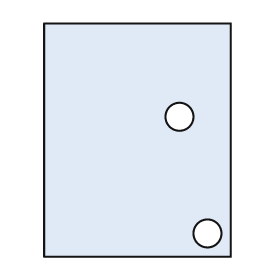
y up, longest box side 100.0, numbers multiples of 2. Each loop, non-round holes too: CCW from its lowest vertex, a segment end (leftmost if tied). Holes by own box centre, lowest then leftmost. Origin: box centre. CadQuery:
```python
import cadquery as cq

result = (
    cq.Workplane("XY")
    .moveTo(-40.0, -50.0)
    .lineTo(40.0, -50.0)
    .lineTo(40.0, 50.0)
    .lineTo(-40.0, 50.0)
    .close()
    .moveTo(30.0, -40.0)
    .circle(6.0)
    .moveTo(18.0, 10.0)
    .circle(6.0)
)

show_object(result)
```